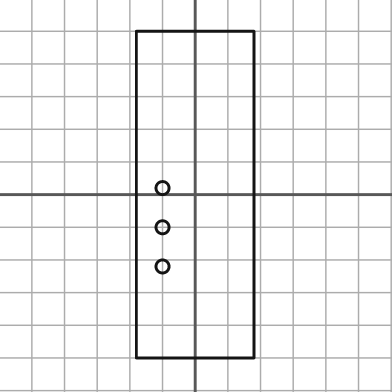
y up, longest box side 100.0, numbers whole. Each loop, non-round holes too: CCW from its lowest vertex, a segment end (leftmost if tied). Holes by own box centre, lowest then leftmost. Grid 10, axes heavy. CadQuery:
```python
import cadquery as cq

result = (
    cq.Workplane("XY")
    .moveTo(-18.0, -50.0)
    .lineTo(18.0, -50.0)
    .lineTo(18.0, 50.0)
    .lineTo(-18.0, 50.0)
    .close()
    .moveTo(-10.0, -22.0)
    .circle(2.0)
    .moveTo(-10.0, -10.0)
    .circle(2.0)
    .moveTo(-10.0, 2.0)
    .circle(2.0)
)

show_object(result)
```